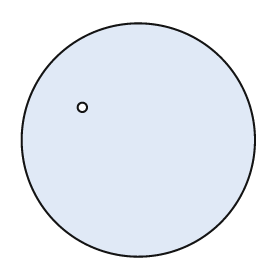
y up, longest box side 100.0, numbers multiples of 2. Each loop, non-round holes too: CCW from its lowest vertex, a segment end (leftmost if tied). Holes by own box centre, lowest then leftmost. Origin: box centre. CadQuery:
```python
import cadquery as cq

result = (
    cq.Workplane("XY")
    .moveTo(0.0, 0.0)
    .circle(50.0)
    .moveTo(-24.0, 14.0)
    .circle(2.0)
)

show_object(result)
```